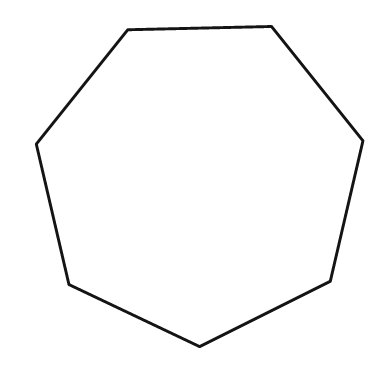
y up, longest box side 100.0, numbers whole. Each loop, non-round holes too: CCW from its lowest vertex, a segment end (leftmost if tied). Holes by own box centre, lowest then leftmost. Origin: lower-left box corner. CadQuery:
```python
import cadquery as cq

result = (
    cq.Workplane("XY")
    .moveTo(50.0, 0.0)
    .lineTo(90.0, 20.0)
    .lineTo(100.0, 63.0)
    .lineTo(72.0, 98.0)
    .lineTo(28.0, 97.0)
    .lineTo(0.0, 62.0)
    .lineTo(10.0, 19.0)
    .close()
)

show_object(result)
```